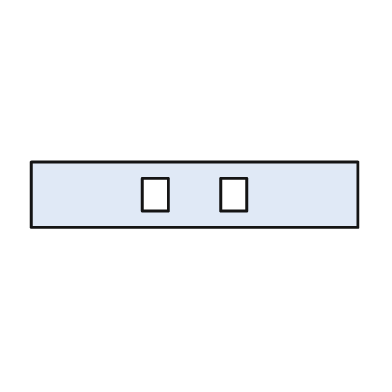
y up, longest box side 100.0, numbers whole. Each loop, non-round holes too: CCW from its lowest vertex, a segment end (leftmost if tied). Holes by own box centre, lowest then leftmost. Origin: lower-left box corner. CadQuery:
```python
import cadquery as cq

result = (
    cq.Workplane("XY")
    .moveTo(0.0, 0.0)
    .lineTo(100.0, 0.0)
    .lineTo(100.0, 20.0)
    .lineTo(0.0, 20.0)
    .close()
    .moveTo(34.0, 5.0)
    .lineTo(42.0, 5.0)
    .lineTo(42.0, 15.0)
    .lineTo(34.0, 15.0)
    .close()
    .moveTo(58.0, 5.0)
    .lineTo(66.0, 5.0)
    .lineTo(66.0, 15.0)
    .lineTo(58.0, 15.0)
    .close()
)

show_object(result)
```